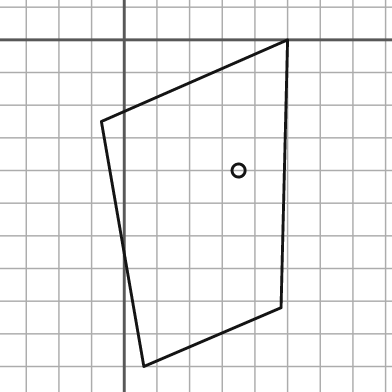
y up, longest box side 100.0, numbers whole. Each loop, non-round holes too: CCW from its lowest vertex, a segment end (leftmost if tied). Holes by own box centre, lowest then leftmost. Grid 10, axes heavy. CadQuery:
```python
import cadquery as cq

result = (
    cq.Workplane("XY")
    .moveTo(6.0, -100.0)
    .lineTo(48.0, -82.0)
    .lineTo(50.0, 0.0)
    .lineTo(-7.0, -25.0)
    .close()
    .moveTo(35.0, -40.0)
    .circle(2.0)
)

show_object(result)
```